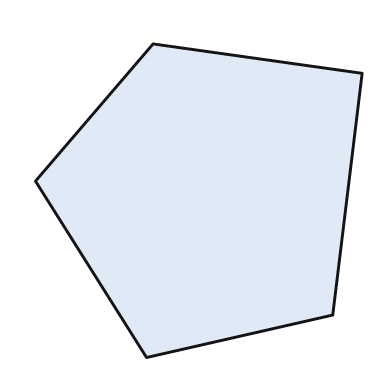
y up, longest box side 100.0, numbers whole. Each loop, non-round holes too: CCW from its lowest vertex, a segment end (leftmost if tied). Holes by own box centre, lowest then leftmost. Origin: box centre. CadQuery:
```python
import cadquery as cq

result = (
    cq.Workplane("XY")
    .moveTo(-16.0, -48.0)
    .lineTo(41.0, -35.0)
    .lineTo(50.0, 39.0)
    .lineTo(-14.0, 48.0)
    .lineTo(-50.0, 6.0)
    .close()
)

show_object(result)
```